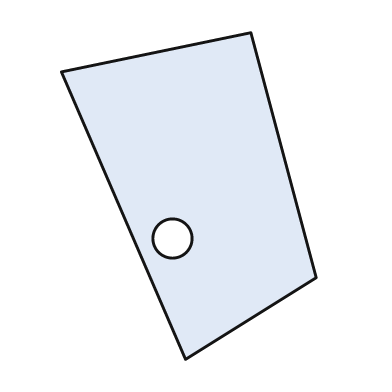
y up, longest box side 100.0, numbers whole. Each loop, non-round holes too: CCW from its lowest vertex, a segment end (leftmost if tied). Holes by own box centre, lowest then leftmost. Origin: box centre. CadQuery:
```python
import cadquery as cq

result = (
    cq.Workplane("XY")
    .moveTo(-1.0, -50.0)
    .lineTo(39.0, -25.0)
    .lineTo(19.0, 50.0)
    .lineTo(-39.0, 38.0)
    .close()
    .moveTo(-5.0, -13.0)
    .circle(6.0)
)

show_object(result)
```